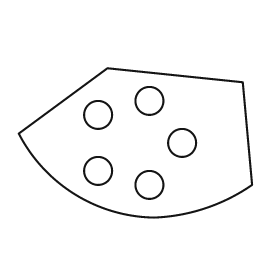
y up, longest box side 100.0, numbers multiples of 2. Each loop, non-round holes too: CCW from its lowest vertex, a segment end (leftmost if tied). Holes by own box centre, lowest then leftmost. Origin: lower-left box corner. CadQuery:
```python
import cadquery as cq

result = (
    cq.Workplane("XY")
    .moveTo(58.0, 0.0)
    .threePointArc((80.0, 4.0), (100.0, 14.0))
    .lineTo(96.0, 58.0)
    .lineTo(38.0, 64.0)
    .lineTo(0.0, 36.0)
    .threePointArc((24.0, 10.0), (58.0, 0.0))
    .close()
    .moveTo(56.0, 14.0)
    .circle(6.0)
    .moveTo(34.0, 20.0)
    .circle(6.0)
    .moveTo(70.0, 32.0)
    .circle(6.0)
    .moveTo(34.0, 44.0)
    .circle(6.0)
    .moveTo(56.0, 50.0)
    .circle(6.0)
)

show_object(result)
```